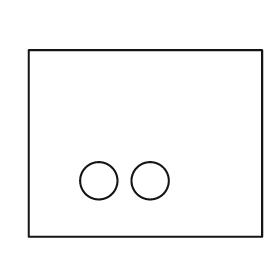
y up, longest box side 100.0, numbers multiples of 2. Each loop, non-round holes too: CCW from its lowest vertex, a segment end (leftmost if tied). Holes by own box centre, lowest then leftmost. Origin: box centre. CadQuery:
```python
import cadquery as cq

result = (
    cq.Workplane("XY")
    .moveTo(-50.0, -40.0)
    .lineTo(50.0, -40.0)
    .lineTo(50.0, 40.0)
    .lineTo(-50.0, 40.0)
    .close()
    .moveTo(-20.0, -16.0)
    .circle(8.0)
    .moveTo(2.0, -16.0)
    .circle(8.0)
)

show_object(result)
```